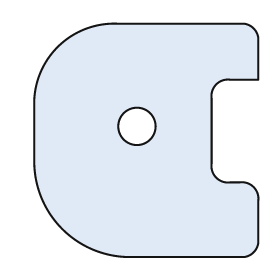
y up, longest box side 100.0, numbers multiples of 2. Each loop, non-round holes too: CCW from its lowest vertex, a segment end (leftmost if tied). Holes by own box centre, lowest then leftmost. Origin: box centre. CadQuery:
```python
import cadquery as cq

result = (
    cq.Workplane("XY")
    .moveTo(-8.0, -50.0)
    .lineTo(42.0, -50.0)
    .threePointArc((46.0, -48.0), (48.0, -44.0))
    .lineTo(48.0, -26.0)
    .threePointArc((46.0, -20.0), (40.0, -18.0))
    .lineTo(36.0, -18.0)
    .threePointArc((30.0, -16.0), (28.0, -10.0))
    .lineTo(28.0, 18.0)
    .threePointArc((30.0, 24.0), (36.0, 26.0))
    .lineTo(48.0, 26.0)
    .lineTo(48.0, 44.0)
    .threePointArc((46.0, 48.0), (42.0, 50.0))
    .lineTo(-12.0, 50.0)
    .threePointArc((-38.0, 40.0), (-48.0, 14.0))
    .lineTo(-48.0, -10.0)
    .threePointArc((-36.0, -38.0), (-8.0, -50.0))
    .close()
    .moveTo(-4.0, 6.0)
    .circle(8.0)
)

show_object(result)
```